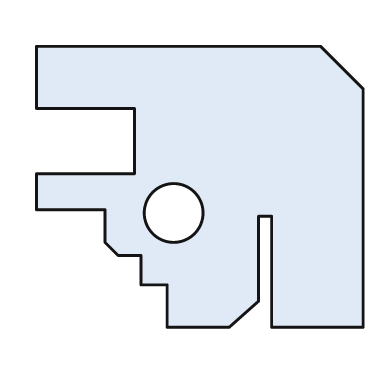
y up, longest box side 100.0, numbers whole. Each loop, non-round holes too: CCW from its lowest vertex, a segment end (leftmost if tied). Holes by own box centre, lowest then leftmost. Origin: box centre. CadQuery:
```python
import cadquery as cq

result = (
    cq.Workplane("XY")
    .moveTo(-10.0, -43.0)
    .lineTo(9.0, -43.0)
    .lineTo(18.0, -35.0)
    .lineTo(18.0, -9.0)
    .lineTo(22.0, -9.0)
    .lineTo(22.0, -43.0)
    .lineTo(50.0, -43.0)
    .lineTo(50.0, 30.0)
    .lineTo(37.0, 43.0)
    .lineTo(-50.0, 43.0)
    .lineTo(-50.0, 24.0)
    .lineTo(-20.0, 24.0)
    .lineTo(-20.0, 4.0)
    .lineTo(-50.0, 4.0)
    .lineTo(-50.0, -7.0)
    .lineTo(-29.0, -7.0)
    .lineTo(-29.0, -17.0)
    .lineTo(-25.0, -21.0)
    .lineTo(-18.0, -21.0)
    .lineTo(-18.0, -30.0)
    .lineTo(-10.0, -30.0)
    .close()
    .moveTo(-8.0, -8.0)
    .circle(9.0)
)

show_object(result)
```